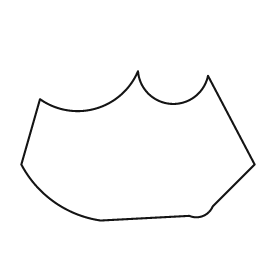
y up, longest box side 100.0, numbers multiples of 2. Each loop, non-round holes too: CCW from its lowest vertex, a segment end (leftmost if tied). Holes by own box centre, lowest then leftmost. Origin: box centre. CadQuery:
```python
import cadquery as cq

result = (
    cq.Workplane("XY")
    .moveTo(-16.0, -32.0)
    .lineTo(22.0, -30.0)
    .threePointArc((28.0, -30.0), (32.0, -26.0))
    .lineTo(50.0, -8.0)
    .lineTo(30.0, 30.0)
    .threePointArc((14.0, 18.0), (0.0, 32.0))
    .threePointArc((-18.0, 16.0), (-42.0, 20.0))
    .lineTo(-50.0, -8.0)
    .threePointArc((-36.0, -24.0), (-16.0, -32.0))
    .close()
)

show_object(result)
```